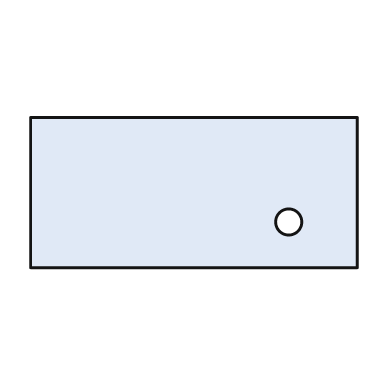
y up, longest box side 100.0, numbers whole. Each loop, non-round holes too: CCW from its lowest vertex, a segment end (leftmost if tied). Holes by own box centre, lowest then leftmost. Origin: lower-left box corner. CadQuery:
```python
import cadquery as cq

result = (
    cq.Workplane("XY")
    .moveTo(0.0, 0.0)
    .lineTo(100.0, 0.0)
    .lineTo(100.0, 46.0)
    .lineTo(0.0, 46.0)
    .close()
    .moveTo(79.0, 14.0)
    .circle(4.0)
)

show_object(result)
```